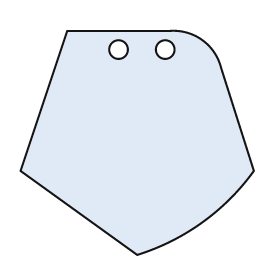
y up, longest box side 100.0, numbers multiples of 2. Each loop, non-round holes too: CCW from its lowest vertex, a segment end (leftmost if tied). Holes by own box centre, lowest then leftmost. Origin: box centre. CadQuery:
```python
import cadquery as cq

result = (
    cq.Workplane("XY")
    .moveTo(0.0, -48.0)
    .threePointArc((28.0, -34.0), (50.0, -12.0))
    .lineTo(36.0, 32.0)
    .threePointArc((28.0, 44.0), (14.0, 48.0))
    .lineTo(-30.0, 48.0)
    .lineTo(-50.0, -12.0)
    .close()
    .moveTo(-8.0, 40.0)
    .circle(4.0)
    .moveTo(12.0, 40.0)
    .circle(4.0)
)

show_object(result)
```